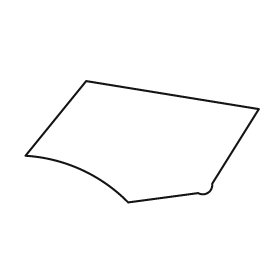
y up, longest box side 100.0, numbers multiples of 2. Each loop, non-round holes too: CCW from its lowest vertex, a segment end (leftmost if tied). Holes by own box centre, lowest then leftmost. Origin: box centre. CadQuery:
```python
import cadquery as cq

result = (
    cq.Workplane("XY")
    .moveTo(-6.0, -26.0)
    .lineTo(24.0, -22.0)
    .threePointArc((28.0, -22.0), (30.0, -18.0))
    .lineTo(50.0, 14.0)
    .lineTo(-24.0, 26.0)
    .lineTo(-50.0, -6.0)
    .threePointArc((-26.0, -12.0), (-6.0, -26.0))
    .close()
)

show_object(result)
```